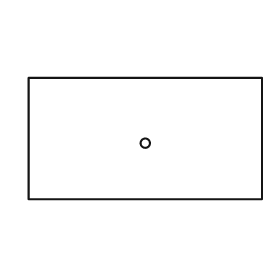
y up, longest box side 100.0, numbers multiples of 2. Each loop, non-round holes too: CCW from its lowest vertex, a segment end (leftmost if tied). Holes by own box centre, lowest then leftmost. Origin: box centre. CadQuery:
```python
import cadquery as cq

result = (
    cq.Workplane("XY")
    .moveTo(-50.0, -26.0)
    .lineTo(50.0, -26.0)
    .lineTo(50.0, 26.0)
    .lineTo(-50.0, 26.0)
    .close()
    .moveTo(0.0, -2.0)
    .circle(2.0)
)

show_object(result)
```